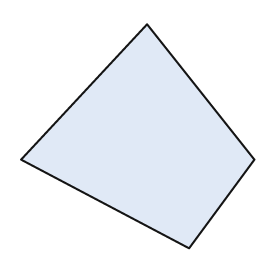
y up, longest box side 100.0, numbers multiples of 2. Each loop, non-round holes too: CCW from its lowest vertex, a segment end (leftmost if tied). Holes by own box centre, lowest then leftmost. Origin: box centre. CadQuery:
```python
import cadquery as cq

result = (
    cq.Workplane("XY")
    .moveTo(22.0, -48.0)
    .lineTo(50.0, -10.0)
    .lineTo(4.0, 48.0)
    .lineTo(-50.0, -10.0)
    .close()
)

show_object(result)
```